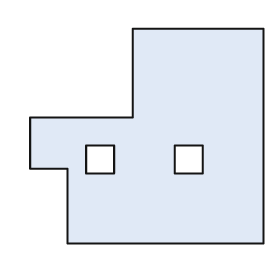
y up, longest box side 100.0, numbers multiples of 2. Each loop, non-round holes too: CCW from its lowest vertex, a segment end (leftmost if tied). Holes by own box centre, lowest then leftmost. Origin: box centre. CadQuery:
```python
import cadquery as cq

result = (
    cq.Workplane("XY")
    .moveTo(-34.0, -46.0)
    .lineTo(50.0, -46.0)
    .lineTo(50.0, 46.0)
    .lineTo(-6.0, 46.0)
    .lineTo(-6.0, 8.0)
    .lineTo(-50.0, 8.0)
    .lineTo(-50.0, -14.0)
    .lineTo(-34.0, -14.0)
    .close()
    .moveTo(-26.0, -16.0)
    .lineTo(-14.0, -16.0)
    .lineTo(-14.0, -4.0)
    .lineTo(-26.0, -4.0)
    .close()
    .moveTo(12.0, -16.0)
    .lineTo(24.0, -16.0)
    .lineTo(24.0, -4.0)
    .lineTo(12.0, -4.0)
    .close()
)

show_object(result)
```